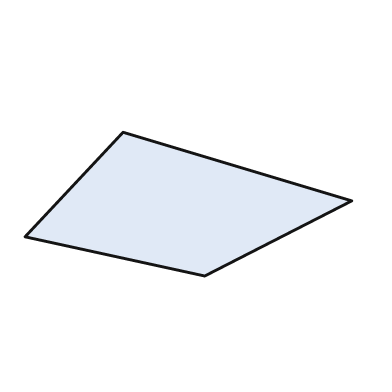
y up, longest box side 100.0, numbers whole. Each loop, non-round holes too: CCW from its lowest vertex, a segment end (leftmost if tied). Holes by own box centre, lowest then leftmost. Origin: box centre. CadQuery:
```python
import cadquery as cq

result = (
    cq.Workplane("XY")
    .moveTo(5.0, -22.0)
    .lineTo(50.0, 1.0)
    .lineTo(-20.0, 22.0)
    .lineTo(-50.0, -10.0)
    .close()
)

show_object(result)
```